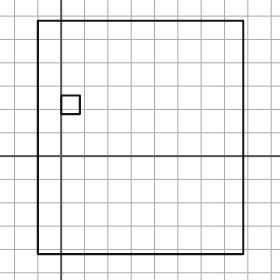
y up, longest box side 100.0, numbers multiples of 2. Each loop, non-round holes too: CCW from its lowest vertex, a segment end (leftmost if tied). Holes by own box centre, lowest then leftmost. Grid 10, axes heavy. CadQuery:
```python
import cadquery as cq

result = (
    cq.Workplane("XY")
    .moveTo(-10.0, -42.0)
    .lineTo(78.0, -42.0)
    .lineTo(78.0, 58.0)
    .lineTo(-10.0, 58.0)
    .close()
    .moveTo(0.0, 18.0)
    .lineTo(8.0, 18.0)
    .lineTo(8.0, 26.0)
    .lineTo(0.0, 26.0)
    .close()
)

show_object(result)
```